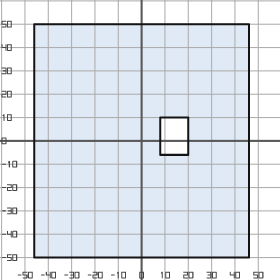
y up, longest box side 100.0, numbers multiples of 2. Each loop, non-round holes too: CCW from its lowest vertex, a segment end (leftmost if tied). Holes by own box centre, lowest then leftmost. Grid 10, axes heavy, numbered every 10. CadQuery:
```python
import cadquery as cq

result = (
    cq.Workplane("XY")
    .moveTo(-46.0, -50.0)
    .lineTo(46.0, -50.0)
    .lineTo(46.0, 50.0)
    .lineTo(-46.0, 50.0)
    .close()
    .moveTo(8.0, -6.0)
    .lineTo(20.0, -6.0)
    .lineTo(20.0, 10.0)
    .lineTo(8.0, 10.0)
    .close()
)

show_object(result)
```